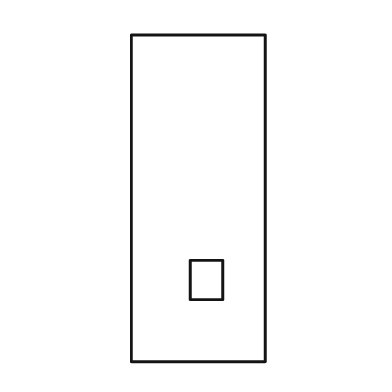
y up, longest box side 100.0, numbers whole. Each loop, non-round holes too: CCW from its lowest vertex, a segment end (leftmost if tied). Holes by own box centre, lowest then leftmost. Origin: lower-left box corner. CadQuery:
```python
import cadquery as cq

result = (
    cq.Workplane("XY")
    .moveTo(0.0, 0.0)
    .lineTo(41.0, 0.0)
    .lineTo(41.0, 100.0)
    .lineTo(0.0, 100.0)
    .close()
    .moveTo(18.0, 19.0)
    .lineTo(28.0, 19.0)
    .lineTo(28.0, 31.0)
    .lineTo(18.0, 31.0)
    .close()
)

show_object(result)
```